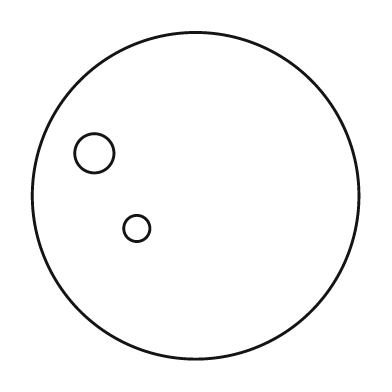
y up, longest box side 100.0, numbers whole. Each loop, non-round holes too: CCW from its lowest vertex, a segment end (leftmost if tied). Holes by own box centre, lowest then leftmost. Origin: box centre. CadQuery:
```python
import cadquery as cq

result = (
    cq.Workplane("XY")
    .moveTo(0.0, 0.0)
    .circle(50.0)
    .moveTo(-18.0, -10.0)
    .circle(4.0)
    .moveTo(-31.0, 13.0)
    .circle(6.0)
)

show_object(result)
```